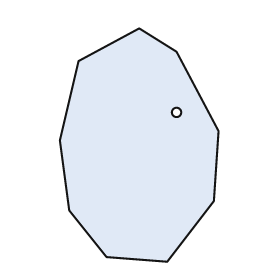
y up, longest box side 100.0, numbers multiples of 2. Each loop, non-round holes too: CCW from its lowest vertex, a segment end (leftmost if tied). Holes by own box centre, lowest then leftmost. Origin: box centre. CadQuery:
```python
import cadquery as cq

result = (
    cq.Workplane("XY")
    .moveTo(12.0, -50.0)
    .lineTo(32.0, -24.0)
    .lineTo(34.0, 6.0)
    .lineTo(16.0, 40.0)
    .lineTo(0.0, 50.0)
    .lineTo(-26.0, 36.0)
    .lineTo(-34.0, 2.0)
    .lineTo(-30.0, -28.0)
    .lineTo(-14.0, -48.0)
    .close()
    .moveTo(16.0, 14.0)
    .circle(2.0)
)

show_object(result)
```